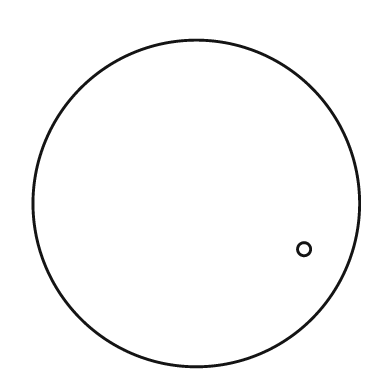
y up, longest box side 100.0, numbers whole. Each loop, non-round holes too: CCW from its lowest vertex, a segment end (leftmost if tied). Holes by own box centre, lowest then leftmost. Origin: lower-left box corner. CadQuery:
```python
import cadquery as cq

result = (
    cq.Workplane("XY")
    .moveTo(50.0, 50.0)
    .circle(50.0)
    .moveTo(83.0, 36.0)
    .circle(2.0)
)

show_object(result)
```